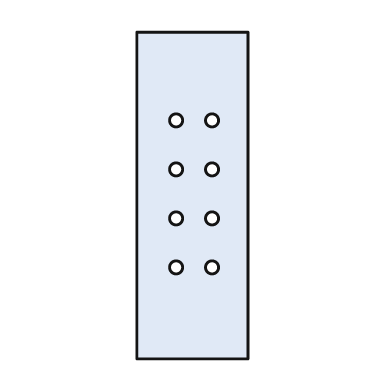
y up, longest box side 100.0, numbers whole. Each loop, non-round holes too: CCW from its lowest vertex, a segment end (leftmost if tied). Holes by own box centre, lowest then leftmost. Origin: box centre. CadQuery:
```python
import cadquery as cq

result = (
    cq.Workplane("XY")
    .moveTo(-17.0, -50.0)
    .lineTo(17.0, -50.0)
    .lineTo(17.0, 50.0)
    .lineTo(-17.0, 50.0)
    .close()
    .moveTo(-5.0, -22.0)
    .circle(2.0)
    .moveTo(6.0, -22.0)
    .circle(2.0)
    .moveTo(-5.0, -7.0)
    .circle(2.0)
    .moveTo(6.0, -7.0)
    .circle(2.0)
    .moveTo(-5.0, 8.0)
    .circle(2.0)
    .moveTo(6.0, 8.0)
    .circle(2.0)
    .moveTo(-5.0, 23.0)
    .circle(2.0)
    .moveTo(6.0, 23.0)
    .circle(2.0)
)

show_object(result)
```